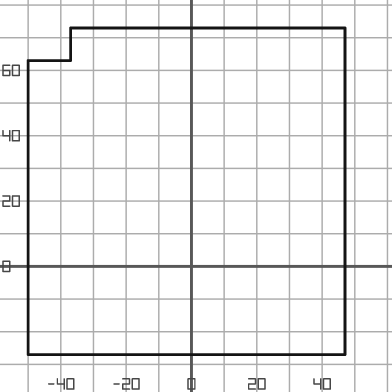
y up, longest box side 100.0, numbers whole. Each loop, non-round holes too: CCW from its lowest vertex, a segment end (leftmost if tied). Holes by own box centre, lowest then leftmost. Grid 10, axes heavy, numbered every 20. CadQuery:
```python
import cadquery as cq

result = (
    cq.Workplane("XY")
    .moveTo(-50.0, -27.0)
    .lineTo(47.0, -27.0)
    .lineTo(47.0, 73.0)
    .lineTo(-37.0, 73.0)
    .lineTo(-37.0, 63.0)
    .lineTo(-50.0, 63.0)
    .close()
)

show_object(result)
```